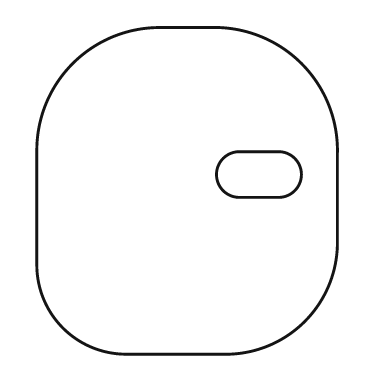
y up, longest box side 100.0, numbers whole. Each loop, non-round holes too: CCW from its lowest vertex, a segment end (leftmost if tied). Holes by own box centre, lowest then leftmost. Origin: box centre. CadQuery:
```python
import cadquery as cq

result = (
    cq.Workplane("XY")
    .moveTo(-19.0, -50.0)
    .lineTo(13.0, -50.0)
    .threePointArc((36.0, -40.0), (46.0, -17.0))
    .lineTo(46.0, 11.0)
    .threePointArc((35.0, 39.0), (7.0, 50.0))
    .lineTo(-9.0, 50.0)
    .threePointArc((-35.0, 39.0), (-46.0, 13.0))
    .lineTo(-46.0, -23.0)
    .threePointArc((-38.0, -42.0), (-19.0, -50.0))
    .close()
    .moveTo(16.0, -2.0)
    .lineTo(28.0, -2.0)
    .threePointArc((35.0, 5.0), (28.0, 12.0))
    .lineTo(16.0, 12.0)
    .threePointArc((9.0, 5.0), (16.0, -2.0))
    .close()
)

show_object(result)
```